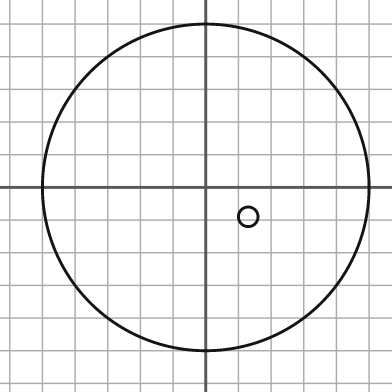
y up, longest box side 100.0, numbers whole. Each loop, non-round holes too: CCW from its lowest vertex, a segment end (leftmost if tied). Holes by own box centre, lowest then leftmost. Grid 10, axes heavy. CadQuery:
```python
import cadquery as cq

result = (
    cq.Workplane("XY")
    .moveTo(0.0, 0.0)
    .circle(50.0)
    .moveTo(13.0, -9.0)
    .circle(3.0)
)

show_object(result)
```